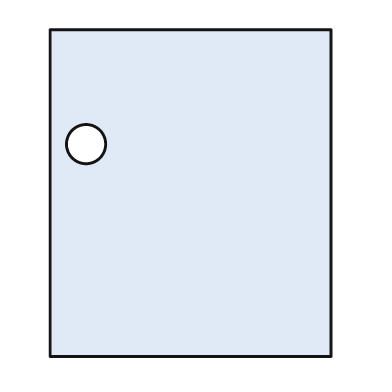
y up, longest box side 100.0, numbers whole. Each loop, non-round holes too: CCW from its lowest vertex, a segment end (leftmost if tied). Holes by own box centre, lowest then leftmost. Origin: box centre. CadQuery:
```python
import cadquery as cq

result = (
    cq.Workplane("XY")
    .moveTo(-43.0, -50.0)
    .lineTo(43.0, -50.0)
    .lineTo(43.0, 50.0)
    .lineTo(-43.0, 50.0)
    .close()
    .moveTo(-32.0, 15.0)
    .circle(6.0)
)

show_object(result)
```